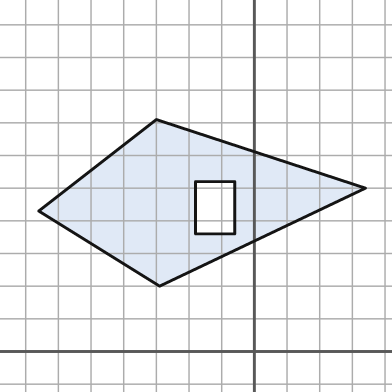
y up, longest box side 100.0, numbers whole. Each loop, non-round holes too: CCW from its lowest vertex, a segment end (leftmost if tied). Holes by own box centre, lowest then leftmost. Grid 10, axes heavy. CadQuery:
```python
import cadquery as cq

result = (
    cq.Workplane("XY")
    .moveTo(-29.0, 20.0)
    .lineTo(34.0, 50.0)
    .lineTo(-30.0, 71.0)
    .lineTo(-66.0, 43.0)
    .close()
    .moveTo(-18.0, 36.0)
    .lineTo(-6.0, 36.0)
    .lineTo(-6.0, 52.0)
    .lineTo(-18.0, 52.0)
    .close()
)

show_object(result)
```